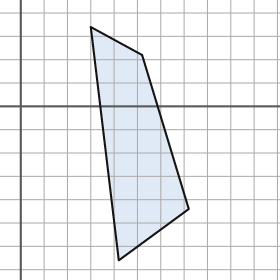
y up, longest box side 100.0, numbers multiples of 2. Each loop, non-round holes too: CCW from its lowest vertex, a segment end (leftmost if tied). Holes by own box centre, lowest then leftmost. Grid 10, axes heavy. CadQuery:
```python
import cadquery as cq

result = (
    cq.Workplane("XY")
    .moveTo(42.0, -66.0)
    .lineTo(72.0, -44.0)
    .lineTo(52.0, 22.0)
    .lineTo(30.0, 34.0)
    .close()
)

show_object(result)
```